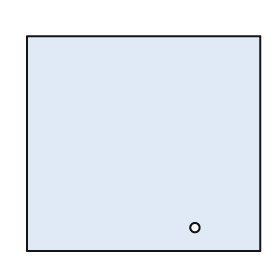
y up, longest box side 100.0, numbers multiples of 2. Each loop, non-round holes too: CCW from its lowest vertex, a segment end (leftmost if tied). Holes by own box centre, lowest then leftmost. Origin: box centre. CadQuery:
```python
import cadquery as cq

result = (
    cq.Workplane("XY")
    .moveTo(-50.0, -46.0)
    .lineTo(50.0, -46.0)
    .lineTo(50.0, 46.0)
    .lineTo(-50.0, 46.0)
    .close()
    .moveTo(22.0, -36.0)
    .circle(2.0)
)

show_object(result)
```